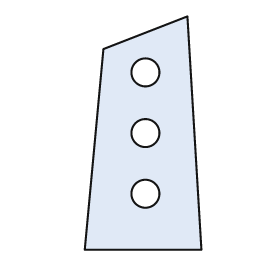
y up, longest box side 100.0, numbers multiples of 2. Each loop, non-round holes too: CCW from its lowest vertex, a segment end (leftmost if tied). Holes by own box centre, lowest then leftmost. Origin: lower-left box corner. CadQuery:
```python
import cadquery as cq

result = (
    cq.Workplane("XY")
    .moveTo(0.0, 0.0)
    .lineTo(50.0, 0.0)
    .lineTo(44.0, 100.0)
    .lineTo(8.0, 86.0)
    .close()
    .moveTo(26.0, 24.0)
    .circle(6.0)
    .moveTo(26.0, 50.0)
    .circle(6.0)
    .moveTo(26.0, 76.0)
    .circle(6.0)
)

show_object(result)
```